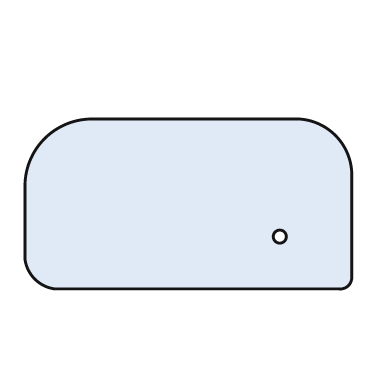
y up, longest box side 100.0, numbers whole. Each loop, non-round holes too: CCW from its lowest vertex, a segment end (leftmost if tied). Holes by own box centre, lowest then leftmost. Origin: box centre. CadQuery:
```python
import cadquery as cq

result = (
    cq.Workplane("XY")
    .moveTo(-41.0, -26.0)
    .lineTo(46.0, -26.0)
    .threePointArc((49.0, -25.0), (50.0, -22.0))
    .lineTo(50.0, 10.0)
    .threePointArc((45.0, 21.0), (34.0, 26.0))
    .lineTo(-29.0, 26.0)
    .threePointArc((-44.0, 20.0), (-50.0, 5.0))
    .lineTo(-50.0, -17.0)
    .threePointArc((-47.0, -23.0), (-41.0, -26.0))
    .close()
    .moveTo(28.0, -10.0)
    .circle(2.0)
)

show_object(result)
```